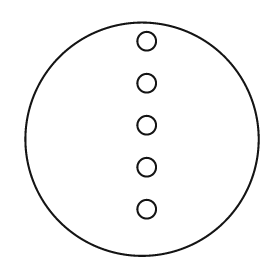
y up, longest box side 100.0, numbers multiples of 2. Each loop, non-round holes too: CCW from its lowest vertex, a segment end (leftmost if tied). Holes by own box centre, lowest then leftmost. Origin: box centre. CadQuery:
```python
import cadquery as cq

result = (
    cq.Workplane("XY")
    .moveTo(0.0, 0.0)
    .circle(50.0)
    .moveTo(2.0, -30.0)
    .circle(4.0)
    .moveTo(2.0, -12.0)
    .circle(4.0)
    .moveTo(2.0, 6.0)
    .circle(4.0)
    .moveTo(2.0, 24.0)
    .circle(4.0)
    .moveTo(2.0, 42.0)
    .circle(4.0)
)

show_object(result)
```